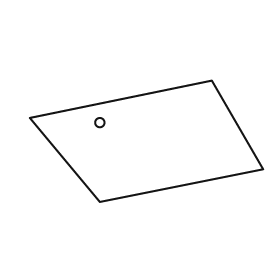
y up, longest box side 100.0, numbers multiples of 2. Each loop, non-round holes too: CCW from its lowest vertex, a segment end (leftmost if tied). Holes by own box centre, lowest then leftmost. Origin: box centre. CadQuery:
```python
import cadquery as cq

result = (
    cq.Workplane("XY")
    .moveTo(-20.0, -26.0)
    .lineTo(50.0, -12.0)
    .lineTo(28.0, 26.0)
    .lineTo(-50.0, 10.0)
    .close()
    .moveTo(-20.0, 8.0)
    .circle(2.0)
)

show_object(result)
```